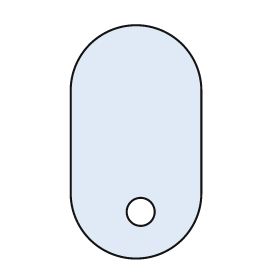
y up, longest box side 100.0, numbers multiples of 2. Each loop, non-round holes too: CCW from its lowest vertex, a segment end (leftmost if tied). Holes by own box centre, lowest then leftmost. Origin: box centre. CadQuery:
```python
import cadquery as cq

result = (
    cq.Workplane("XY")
    .moveTo(-28.0, -22.0)
    .threePointArc((0.0, -50.0), (28.0, -22.0))
    .lineTo(28.0, 22.0)
    .threePointArc((0.0, 50.0), (-28.0, 22.0))
    .close()
    .moveTo(2.0, -30.0)
    .circle(6.0)
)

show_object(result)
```